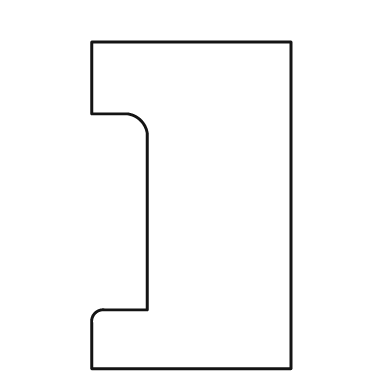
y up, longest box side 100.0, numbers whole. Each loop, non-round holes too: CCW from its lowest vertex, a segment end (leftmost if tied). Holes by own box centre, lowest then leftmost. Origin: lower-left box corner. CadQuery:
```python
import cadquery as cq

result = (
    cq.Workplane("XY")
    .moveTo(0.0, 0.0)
    .lineTo(61.0, 0.0)
    .lineTo(61.0, 100.0)
    .lineTo(0.0, 100.0)
    .lineTo(0.0, 78.0)
    .lineTo(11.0, 78.0)
    .threePointArc((15.0, 76.0), (17.0, 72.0))
    .lineTo(17.0, 18.0)
    .lineTo(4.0, 18.0)
    .threePointArc((1.0, 17.0), (0.0, 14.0))
    .close()
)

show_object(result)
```